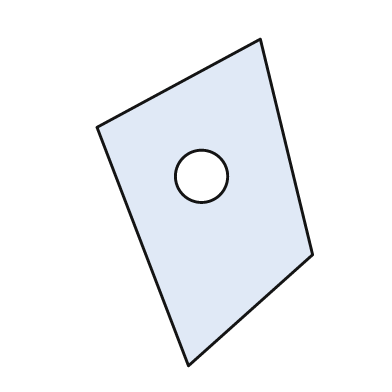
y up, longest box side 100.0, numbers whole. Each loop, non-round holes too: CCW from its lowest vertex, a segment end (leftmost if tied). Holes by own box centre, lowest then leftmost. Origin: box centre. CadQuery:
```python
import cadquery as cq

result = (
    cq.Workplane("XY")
    .moveTo(-5.0, -50.0)
    .lineTo(33.0, -16.0)
    .lineTo(17.0, 50.0)
    .lineTo(-33.0, 23.0)
    .close()
    .moveTo(-1.0, 8.0)
    .circle(8.0)
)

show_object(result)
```